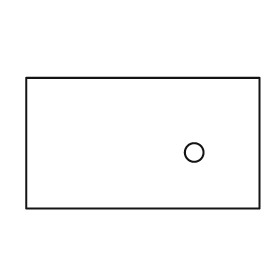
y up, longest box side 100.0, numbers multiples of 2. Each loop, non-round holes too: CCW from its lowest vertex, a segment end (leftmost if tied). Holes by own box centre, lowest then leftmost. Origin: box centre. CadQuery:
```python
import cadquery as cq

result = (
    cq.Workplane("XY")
    .moveTo(-50.0, -28.0)
    .lineTo(50.0, -28.0)
    .lineTo(50.0, 28.0)
    .lineTo(-50.0, 28.0)
    .close()
    .moveTo(22.0, -4.0)
    .circle(4.0)
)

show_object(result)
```